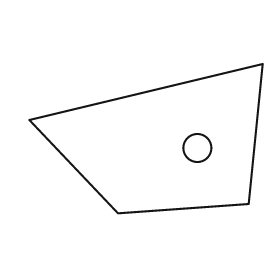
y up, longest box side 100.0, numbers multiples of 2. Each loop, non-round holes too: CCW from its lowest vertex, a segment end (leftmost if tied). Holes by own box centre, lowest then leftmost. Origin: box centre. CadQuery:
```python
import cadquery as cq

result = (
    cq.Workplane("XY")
    .moveTo(-12.0, -32.0)
    .lineTo(44.0, -28.0)
    .lineTo(50.0, 32.0)
    .lineTo(-50.0, 8.0)
    .close()
    .moveTo(22.0, -4.0)
    .circle(6.0)
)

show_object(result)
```